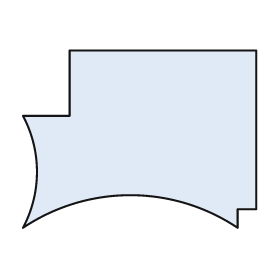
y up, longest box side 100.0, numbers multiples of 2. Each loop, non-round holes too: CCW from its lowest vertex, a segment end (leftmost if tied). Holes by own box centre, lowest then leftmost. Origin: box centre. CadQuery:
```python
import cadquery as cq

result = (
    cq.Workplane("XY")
    .moveTo(-50.0, -38.0)
    .threePointArc((-4.0, -24.0), (42.0, -38.0))
    .lineTo(42.0, -30.0)
    .lineTo(50.0, -30.0)
    .lineTo(50.0, 38.0)
    .lineTo(-30.0, 38.0)
    .lineTo(-30.0, 10.0)
    .lineTo(-50.0, 10.0)
    .threePointArc((-44.0, -14.0), (-50.0, -38.0))
    .close()
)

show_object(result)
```